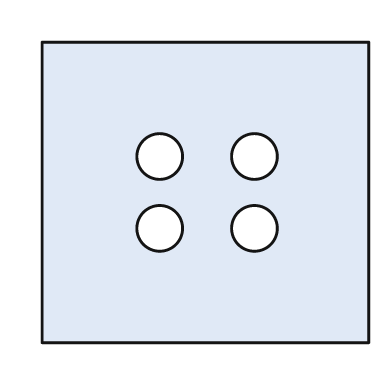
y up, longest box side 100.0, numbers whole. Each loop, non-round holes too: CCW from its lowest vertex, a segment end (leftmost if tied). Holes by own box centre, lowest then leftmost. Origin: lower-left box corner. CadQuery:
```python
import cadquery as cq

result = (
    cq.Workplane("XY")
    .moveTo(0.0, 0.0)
    .lineTo(100.0, 0.0)
    .lineTo(100.0, 92.0)
    .lineTo(0.0, 92.0)
    .close()
    .moveTo(36.0, 35.0)
    .circle(7.0)
    .moveTo(65.0, 35.0)
    .circle(7.0)
    .moveTo(36.0, 57.0)
    .circle(7.0)
    .moveTo(65.0, 57.0)
    .circle(7.0)
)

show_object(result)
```